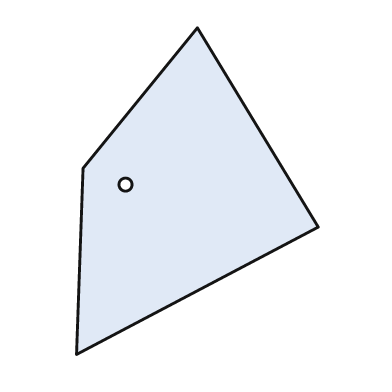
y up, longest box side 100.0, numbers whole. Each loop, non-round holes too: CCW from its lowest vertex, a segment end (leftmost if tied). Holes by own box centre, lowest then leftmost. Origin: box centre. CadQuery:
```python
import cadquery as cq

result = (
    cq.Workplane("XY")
    .moveTo(-37.0, -50.0)
    .lineTo(37.0, -11.0)
    .lineTo(0.0, 50.0)
    .lineTo(-35.0, 7.0)
    .close()
    .moveTo(-22.0, 2.0)
    .circle(2.0)
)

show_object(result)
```